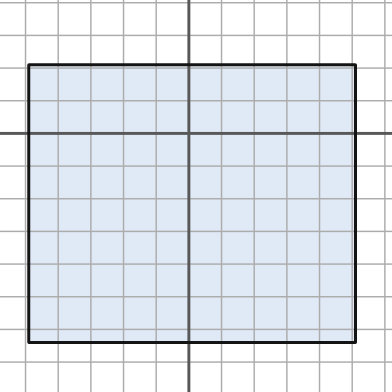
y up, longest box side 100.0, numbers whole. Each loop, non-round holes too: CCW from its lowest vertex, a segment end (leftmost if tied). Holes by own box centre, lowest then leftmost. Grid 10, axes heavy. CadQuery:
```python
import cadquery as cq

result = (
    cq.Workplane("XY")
    .moveTo(-49.0, -64.0)
    .lineTo(51.0, -64.0)
    .lineTo(51.0, 21.0)
    .lineTo(-49.0, 21.0)
    .close()
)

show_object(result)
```